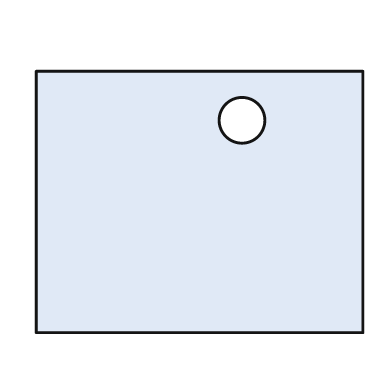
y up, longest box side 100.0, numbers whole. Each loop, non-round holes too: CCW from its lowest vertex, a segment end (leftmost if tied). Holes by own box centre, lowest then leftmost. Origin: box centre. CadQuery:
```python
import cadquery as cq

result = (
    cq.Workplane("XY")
    .moveTo(-50.0, -40.0)
    .lineTo(50.0, -40.0)
    .lineTo(50.0, 40.0)
    .lineTo(-50.0, 40.0)
    .close()
    .moveTo(13.0, 25.0)
    .circle(7.0)
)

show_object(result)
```